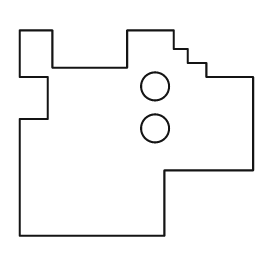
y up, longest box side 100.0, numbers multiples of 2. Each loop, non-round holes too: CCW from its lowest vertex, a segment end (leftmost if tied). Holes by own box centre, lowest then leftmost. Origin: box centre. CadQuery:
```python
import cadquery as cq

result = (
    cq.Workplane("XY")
    .moveTo(-50.0, -44.0)
    .lineTo(12.0, -44.0)
    .lineTo(12.0, -16.0)
    .lineTo(50.0, -16.0)
    .lineTo(50.0, 24.0)
    .lineTo(30.0, 24.0)
    .lineTo(30.0, 30.0)
    .lineTo(22.0, 30.0)
    .lineTo(22.0, 36.0)
    .lineTo(16.0, 36.0)
    .lineTo(16.0, 44.0)
    .lineTo(-4.0, 44.0)
    .lineTo(-4.0, 28.0)
    .lineTo(-36.0, 28.0)
    .lineTo(-36.0, 44.0)
    .lineTo(-50.0, 44.0)
    .lineTo(-50.0, 24.0)
    .lineTo(-38.0, 24.0)
    .lineTo(-38.0, 6.0)
    .lineTo(-50.0, 6.0)
    .close()
    .moveTo(8.0, 2.0)
    .circle(6.0)
    .moveTo(8.0, 20.0)
    .circle(6.0)
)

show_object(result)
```